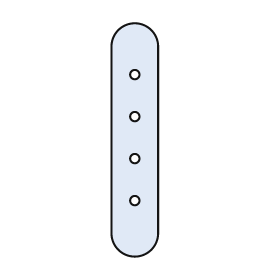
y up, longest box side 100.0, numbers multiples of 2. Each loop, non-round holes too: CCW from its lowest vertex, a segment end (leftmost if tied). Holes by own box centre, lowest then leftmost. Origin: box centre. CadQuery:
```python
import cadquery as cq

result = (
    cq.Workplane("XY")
    .moveTo(-10.0, -40.0)
    .threePointArc((0.0, -50.0), (10.0, -40.0))
    .lineTo(10.0, 40.0)
    .threePointArc((0.0, 50.0), (-10.0, 40.0))
    .close()
    .moveTo(0.0, -26.0)
    .circle(2.0)
    .moveTo(0.0, -8.0)
    .circle(2.0)
    .moveTo(0.0, 10.0)
    .circle(2.0)
    .moveTo(0.0, 28.0)
    .circle(2.0)
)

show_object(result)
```